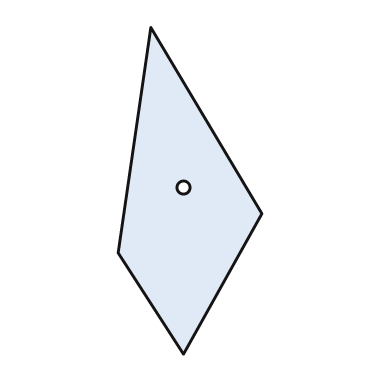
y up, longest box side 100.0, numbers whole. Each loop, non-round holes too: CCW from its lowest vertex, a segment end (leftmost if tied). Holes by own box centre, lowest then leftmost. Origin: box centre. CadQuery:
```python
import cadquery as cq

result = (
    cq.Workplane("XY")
    .moveTo(-2.0, -50.0)
    .lineTo(22.0, -7.0)
    .lineTo(-12.0, 50.0)
    .lineTo(-22.0, -19.0)
    .close()
    .moveTo(-2.0, 1.0)
    .circle(2.0)
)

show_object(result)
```